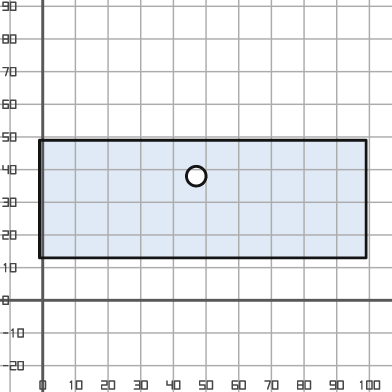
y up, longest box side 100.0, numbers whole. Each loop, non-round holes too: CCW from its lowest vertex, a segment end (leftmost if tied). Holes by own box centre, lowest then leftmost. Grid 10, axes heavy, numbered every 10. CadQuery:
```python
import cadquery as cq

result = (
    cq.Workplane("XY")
    .moveTo(-1.0, 13.0)
    .lineTo(99.0, 13.0)
    .lineTo(99.0, 49.0)
    .lineTo(-1.0, 49.0)
    .close()
    .moveTo(47.0, 38.0)
    .circle(3.0)
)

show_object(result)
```